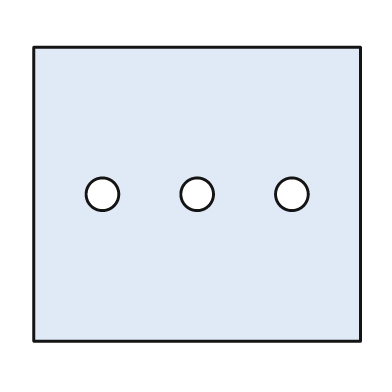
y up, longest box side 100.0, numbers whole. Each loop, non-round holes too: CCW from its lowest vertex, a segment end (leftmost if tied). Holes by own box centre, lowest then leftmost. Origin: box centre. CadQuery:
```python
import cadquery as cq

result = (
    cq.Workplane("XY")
    .moveTo(-50.0, -45.0)
    .lineTo(50.0, -45.0)
    .lineTo(50.0, 45.0)
    .lineTo(-50.0, 45.0)
    .close()
    .moveTo(-29.0, 0.0)
    .circle(5.0)
    .moveTo(0.0, 0.0)
    .circle(5.0)
    .moveTo(29.0, 0.0)
    .circle(5.0)
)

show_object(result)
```